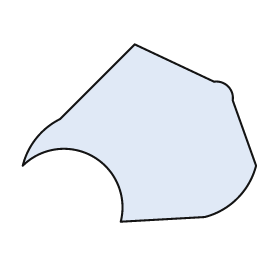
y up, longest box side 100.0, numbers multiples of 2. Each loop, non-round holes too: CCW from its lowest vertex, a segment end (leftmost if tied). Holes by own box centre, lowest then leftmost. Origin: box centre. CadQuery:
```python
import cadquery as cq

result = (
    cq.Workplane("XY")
    .moveTo(-8.0, -38.0)
    .lineTo(28.0, -36.0)
    .threePointArc((42.0, -28.0), (50.0, -14.0))
    .lineTo(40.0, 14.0)
    .threePointArc((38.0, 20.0), (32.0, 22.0))
    .lineTo(-2.0, 38.0)
    .lineTo(-34.0, 6.0)
    .threePointArc((-44.0, -2.0), (-50.0, -14.0))
    .threePointArc((-20.0, -10.0), (-8.0, -38.0))
    .close()
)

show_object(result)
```